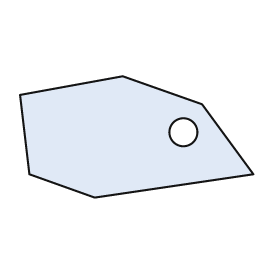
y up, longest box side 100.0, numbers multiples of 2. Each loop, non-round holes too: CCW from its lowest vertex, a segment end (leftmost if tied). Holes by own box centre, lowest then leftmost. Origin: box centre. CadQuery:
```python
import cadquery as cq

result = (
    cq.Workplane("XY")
    .moveTo(-18.0, -26.0)
    .lineTo(50.0, -16.0)
    .lineTo(28.0, 14.0)
    .lineTo(-6.0, 26.0)
    .lineTo(-50.0, 18.0)
    .lineTo(-46.0, -16.0)
    .close()
    .moveTo(20.0, 2.0)
    .circle(6.0)
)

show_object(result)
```